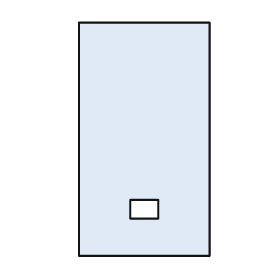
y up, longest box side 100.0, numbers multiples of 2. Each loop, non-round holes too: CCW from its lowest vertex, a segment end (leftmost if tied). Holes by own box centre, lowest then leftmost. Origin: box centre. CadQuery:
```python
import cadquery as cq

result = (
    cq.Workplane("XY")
    .moveTo(-28.0, -50.0)
    .lineTo(28.0, -50.0)
    .lineTo(28.0, 50.0)
    .lineTo(-28.0, 50.0)
    .close()
    .moveTo(-6.0, -34.0)
    .lineTo(6.0, -34.0)
    .lineTo(6.0, -26.0)
    .lineTo(-6.0, -26.0)
    .close()
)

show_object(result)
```